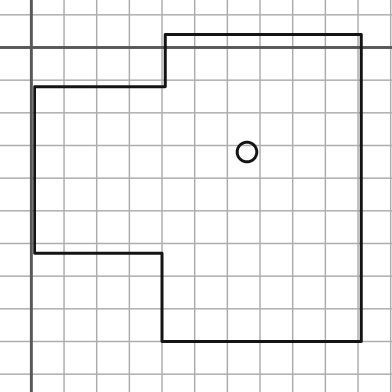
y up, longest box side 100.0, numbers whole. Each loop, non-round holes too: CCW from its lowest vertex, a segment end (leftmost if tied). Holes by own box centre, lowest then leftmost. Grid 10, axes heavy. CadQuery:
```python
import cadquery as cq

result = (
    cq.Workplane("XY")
    .moveTo(40.0, -90.0)
    .lineTo(101.0, -90.0)
    .lineTo(101.0, 4.0)
    .lineTo(41.0, 4.0)
    .lineTo(41.0, -12.0)
    .lineTo(1.0, -12.0)
    .lineTo(1.0, -63.0)
    .lineTo(40.0, -63.0)
    .close()
    .moveTo(66.0, -32.0)
    .circle(3.0)
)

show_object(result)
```